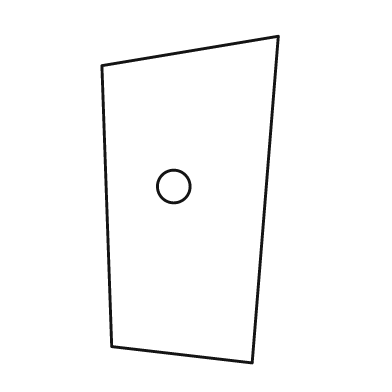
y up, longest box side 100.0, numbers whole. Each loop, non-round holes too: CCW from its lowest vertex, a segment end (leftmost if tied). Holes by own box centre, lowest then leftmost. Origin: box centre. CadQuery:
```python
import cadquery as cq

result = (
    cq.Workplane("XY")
    .moveTo(19.0, -50.0)
    .lineTo(27.0, 50.0)
    .lineTo(-27.0, 41.0)
    .lineTo(-24.0, -45.0)
    .close()
    .moveTo(-5.0, 4.0)
    .circle(5.0)
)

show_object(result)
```